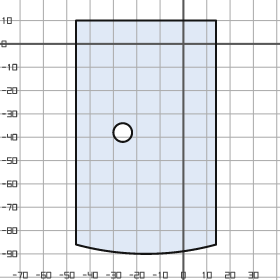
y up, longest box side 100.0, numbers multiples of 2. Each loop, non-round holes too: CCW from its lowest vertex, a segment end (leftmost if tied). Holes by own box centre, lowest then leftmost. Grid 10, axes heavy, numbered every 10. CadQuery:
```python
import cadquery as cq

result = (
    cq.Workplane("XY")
    .moveTo(-46.0, -86.0)
    .threePointArc((-16.0, -90.0), (14.0, -86.0))
    .lineTo(14.0, 10.0)
    .lineTo(-46.0, 10.0)
    .close()
    .moveTo(-26.0, -38.0)
    .circle(4.0)
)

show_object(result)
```